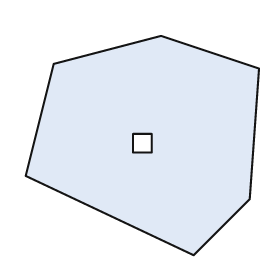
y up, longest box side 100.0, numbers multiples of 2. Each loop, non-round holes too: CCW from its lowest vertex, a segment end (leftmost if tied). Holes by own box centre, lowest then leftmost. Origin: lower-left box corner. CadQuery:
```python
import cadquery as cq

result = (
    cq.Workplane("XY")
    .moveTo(72.0, 0.0)
    .lineTo(96.0, 24.0)
    .lineTo(100.0, 80.0)
    .lineTo(58.0, 94.0)
    .lineTo(12.0, 82.0)
    .lineTo(0.0, 34.0)
    .close()
    .moveTo(46.0, 44.0)
    .lineTo(54.0, 44.0)
    .lineTo(54.0, 52.0)
    .lineTo(46.0, 52.0)
    .close()
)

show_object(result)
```